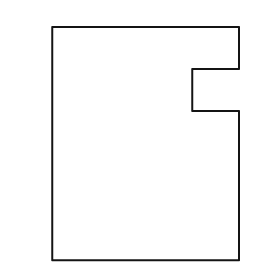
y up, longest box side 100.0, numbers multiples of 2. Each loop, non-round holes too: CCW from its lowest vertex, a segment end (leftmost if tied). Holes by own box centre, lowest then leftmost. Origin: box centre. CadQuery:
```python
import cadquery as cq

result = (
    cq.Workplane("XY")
    .moveTo(-40.0, -50.0)
    .lineTo(40.0, -50.0)
    .lineTo(40.0, 14.0)
    .lineTo(20.0, 14.0)
    .lineTo(20.0, 32.0)
    .lineTo(40.0, 32.0)
    .lineTo(40.0, 50.0)
    .lineTo(-40.0, 50.0)
    .close()
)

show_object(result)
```